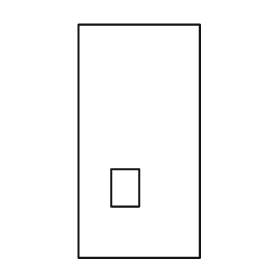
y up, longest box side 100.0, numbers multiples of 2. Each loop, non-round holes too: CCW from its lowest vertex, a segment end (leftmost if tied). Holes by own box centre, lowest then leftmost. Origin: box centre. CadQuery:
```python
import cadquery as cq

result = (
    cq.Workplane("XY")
    .moveTo(-26.0, -50.0)
    .lineTo(26.0, -50.0)
    .lineTo(26.0, 50.0)
    .lineTo(-26.0, 50.0)
    .close()
    .moveTo(-12.0, -28.0)
    .lineTo(0.0, -28.0)
    .lineTo(0.0, -12.0)
    .lineTo(-12.0, -12.0)
    .close()
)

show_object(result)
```